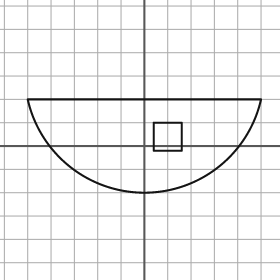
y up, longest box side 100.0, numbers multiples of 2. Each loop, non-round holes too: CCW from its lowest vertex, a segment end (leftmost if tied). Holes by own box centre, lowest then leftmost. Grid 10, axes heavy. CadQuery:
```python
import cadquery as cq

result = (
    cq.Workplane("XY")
    .moveTo(-50.0, 20.0)
    .threePointArc((0.0, -20.0), (50.0, 20.0))
    .close()
    .moveTo(4.0, -2.0)
    .lineTo(16.0, -2.0)
    .lineTo(16.0, 10.0)
    .lineTo(4.0, 10.0)
    .close()
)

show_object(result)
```